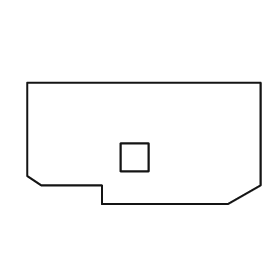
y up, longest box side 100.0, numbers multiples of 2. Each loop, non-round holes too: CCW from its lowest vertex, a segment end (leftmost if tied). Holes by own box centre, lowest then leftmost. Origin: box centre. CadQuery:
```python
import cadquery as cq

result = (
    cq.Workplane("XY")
    .moveTo(-18.0, -26.0)
    .lineTo(36.0, -26.0)
    .lineTo(50.0, -18.0)
    .lineTo(50.0, 26.0)
    .lineTo(-50.0, 26.0)
    .lineTo(-50.0, -14.0)
    .lineTo(-44.0, -18.0)
    .lineTo(-18.0, -18.0)
    .close()
    .moveTo(-10.0, -12.0)
    .lineTo(2.0, -12.0)
    .lineTo(2.0, 0.0)
    .lineTo(-10.0, 0.0)
    .close()
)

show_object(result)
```